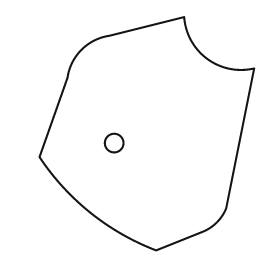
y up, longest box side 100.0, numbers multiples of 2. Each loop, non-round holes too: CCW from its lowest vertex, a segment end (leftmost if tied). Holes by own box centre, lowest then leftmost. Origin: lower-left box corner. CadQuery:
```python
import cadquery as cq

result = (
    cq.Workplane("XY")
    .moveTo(50.0, 0.0)
    .lineTo(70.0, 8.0)
    .threePointArc((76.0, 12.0), (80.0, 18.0))
    .lineTo(92.0, 78.0)
    .threePointArc((72.0, 82.0), (62.0, 100.0))
    .lineTo(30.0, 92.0)
    .threePointArc((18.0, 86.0), (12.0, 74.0))
    .lineTo(0.0, 40.0)
    .threePointArc((22.0, 16.0), (50.0, 0.0))
    .close()
    .moveTo(32.0, 46.0)
    .circle(4.0)
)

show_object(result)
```